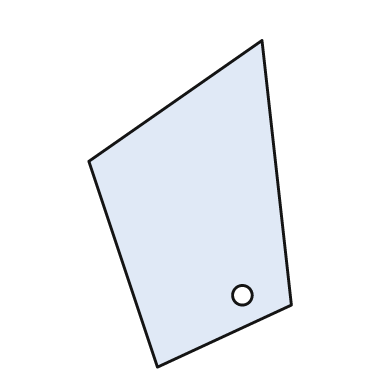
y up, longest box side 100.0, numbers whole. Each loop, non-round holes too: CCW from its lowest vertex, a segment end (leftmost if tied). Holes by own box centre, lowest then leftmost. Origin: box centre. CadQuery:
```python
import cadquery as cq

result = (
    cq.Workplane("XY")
    .moveTo(-10.0, -50.0)
    .lineTo(31.0, -31.0)
    .lineTo(22.0, 50.0)
    .lineTo(-31.0, 13.0)
    .close()
    .moveTo(16.0, -28.0)
    .circle(3.0)
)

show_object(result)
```